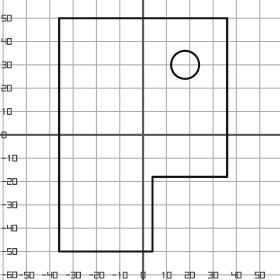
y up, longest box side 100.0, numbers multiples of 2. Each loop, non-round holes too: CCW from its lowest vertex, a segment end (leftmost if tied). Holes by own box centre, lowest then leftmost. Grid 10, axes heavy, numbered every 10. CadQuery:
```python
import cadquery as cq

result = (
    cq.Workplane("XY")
    .moveTo(-36.0, -50.0)
    .lineTo(4.0, -50.0)
    .lineTo(4.0, -18.0)
    .lineTo(36.0, -18.0)
    .lineTo(36.0, 50.0)
    .lineTo(-36.0, 50.0)
    .close()
    .moveTo(18.0, 30.0)
    .circle(6.0)
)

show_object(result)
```